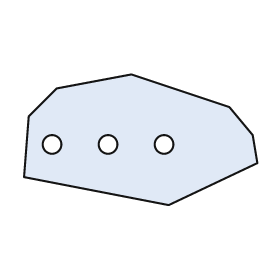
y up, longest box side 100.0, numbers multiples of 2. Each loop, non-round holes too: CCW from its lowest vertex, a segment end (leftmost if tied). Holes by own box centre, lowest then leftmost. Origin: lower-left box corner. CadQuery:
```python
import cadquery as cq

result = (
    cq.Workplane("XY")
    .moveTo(62.0, 0.0)
    .lineTo(100.0, 18.0)
    .lineTo(98.0, 30.0)
    .lineTo(88.0, 42.0)
    .lineTo(46.0, 56.0)
    .lineTo(14.0, 50.0)
    .lineTo(2.0, 38.0)
    .lineTo(0.0, 12.0)
    .close()
    .moveTo(12.0, 26.0)
    .circle(4.0)
    .moveTo(36.0, 26.0)
    .circle(4.0)
    .moveTo(60.0, 26.0)
    .circle(4.0)
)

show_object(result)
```